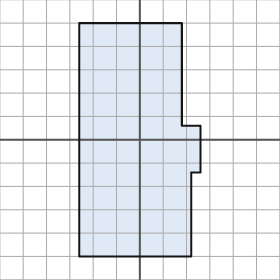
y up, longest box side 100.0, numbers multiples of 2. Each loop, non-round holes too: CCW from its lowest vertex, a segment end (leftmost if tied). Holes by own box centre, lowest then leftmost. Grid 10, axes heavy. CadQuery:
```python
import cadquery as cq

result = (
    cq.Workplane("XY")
    .moveTo(-26.0, -50.0)
    .lineTo(22.0, -50.0)
    .lineTo(22.0, -14.0)
    .lineTo(26.0, -14.0)
    .lineTo(26.0, 6.0)
    .lineTo(18.0, 6.0)
    .lineTo(18.0, 50.0)
    .lineTo(-26.0, 50.0)
    .close()
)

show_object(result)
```